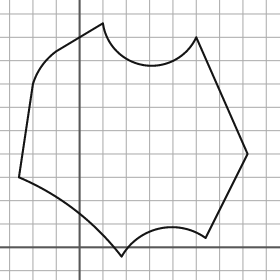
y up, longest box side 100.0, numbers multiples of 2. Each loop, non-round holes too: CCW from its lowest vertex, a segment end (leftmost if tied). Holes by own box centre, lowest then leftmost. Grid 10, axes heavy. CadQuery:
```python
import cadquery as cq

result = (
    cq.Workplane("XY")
    .moveTo(18.0, -4.0)
    .threePointArc((34.0, 8.0), (54.0, 4.0))
    .lineTo(72.0, 40.0)
    .lineTo(50.0, 90.0)
    .threePointArc((28.0, 78.0), (10.0, 96.0))
    .lineTo(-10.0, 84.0)
    .threePointArc((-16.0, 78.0), (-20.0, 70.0))
    .lineTo(-26.0, 30.0)
    .threePointArc((-2.0, 16.0), (18.0, -4.0))
    .close()
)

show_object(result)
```